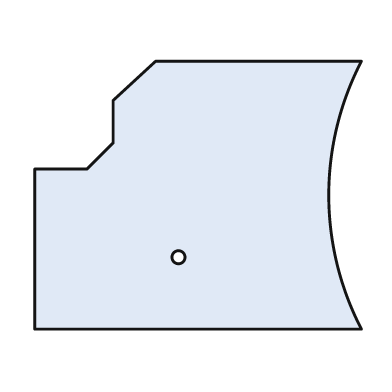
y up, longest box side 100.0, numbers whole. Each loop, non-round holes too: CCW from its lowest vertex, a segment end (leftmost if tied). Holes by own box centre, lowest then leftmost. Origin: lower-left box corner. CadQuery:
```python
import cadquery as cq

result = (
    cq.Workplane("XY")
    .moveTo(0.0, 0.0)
    .lineTo(100.0, 0.0)
    .threePointArc((90.0, 41.0), (100.0, 82.0))
    .lineTo(37.0, 82.0)
    .lineTo(24.0, 70.0)
    .lineTo(24.0, 57.0)
    .lineTo(16.0, 49.0)
    .lineTo(0.0, 49.0)
    .close()
    .moveTo(44.0, 22.0)
    .circle(2.0)
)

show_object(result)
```